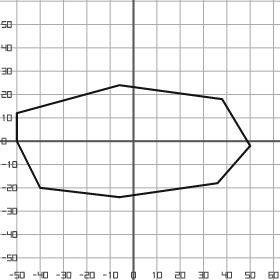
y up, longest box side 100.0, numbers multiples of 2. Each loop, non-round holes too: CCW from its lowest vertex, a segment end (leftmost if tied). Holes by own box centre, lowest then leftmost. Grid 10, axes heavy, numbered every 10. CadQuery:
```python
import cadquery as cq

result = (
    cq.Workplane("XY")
    .moveTo(-6.0, -24.0)
    .lineTo(36.0, -18.0)
    .lineTo(50.0, -2.0)
    .lineTo(38.0, 18.0)
    .lineTo(-6.0, 24.0)
    .lineTo(-50.0, 12.0)
    .lineTo(-50.0, 0.0)
    .lineTo(-40.0, -20.0)
    .close()
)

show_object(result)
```